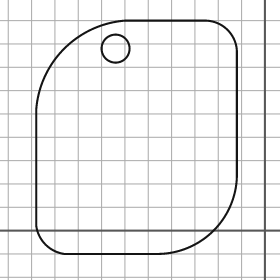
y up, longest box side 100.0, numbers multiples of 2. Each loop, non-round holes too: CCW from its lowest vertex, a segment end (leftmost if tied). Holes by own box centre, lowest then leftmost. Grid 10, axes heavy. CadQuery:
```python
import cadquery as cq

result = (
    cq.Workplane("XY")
    .moveTo(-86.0, -10.0)
    .lineTo(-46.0, -10.0)
    .threePointArc((-22.0, 0.0), (-12.0, 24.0))
    .lineTo(-12.0, 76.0)
    .threePointArc((-16.0, 86.0), (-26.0, 90.0))
    .lineTo(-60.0, 90.0)
    .threePointArc((-86.0, 78.0), (-98.0, 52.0))
    .lineTo(-98.0, 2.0)
    .threePointArc((-94.0, -6.0), (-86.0, -10.0))
    .close()
    .moveTo(-64.0, 78.0)
    .circle(6.0)
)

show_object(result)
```